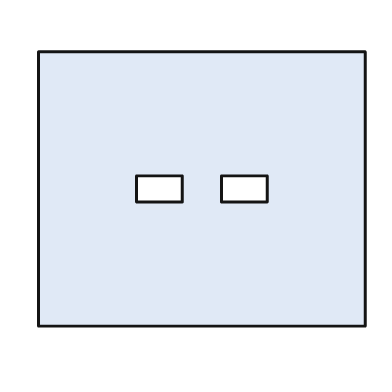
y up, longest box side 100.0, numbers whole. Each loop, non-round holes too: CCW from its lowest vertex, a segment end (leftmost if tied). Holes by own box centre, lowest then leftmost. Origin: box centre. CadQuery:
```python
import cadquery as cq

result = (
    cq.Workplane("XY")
    .moveTo(-50.0, -42.0)
    .lineTo(50.0, -42.0)
    .lineTo(50.0, 42.0)
    .lineTo(-50.0, 42.0)
    .close()
    .moveTo(-20.0, -4.0)
    .lineTo(-6.0, -4.0)
    .lineTo(-6.0, 4.0)
    .lineTo(-20.0, 4.0)
    .close()
    .moveTo(6.0, -4.0)
    .lineTo(20.0, -4.0)
    .lineTo(20.0, 4.0)
    .lineTo(6.0, 4.0)
    .close()
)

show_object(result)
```